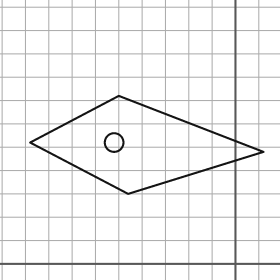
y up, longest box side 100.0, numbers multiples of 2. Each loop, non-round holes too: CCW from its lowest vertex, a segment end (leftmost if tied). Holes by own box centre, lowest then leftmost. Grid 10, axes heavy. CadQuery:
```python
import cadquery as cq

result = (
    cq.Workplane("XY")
    .moveTo(-46.0, 30.0)
    .lineTo(12.0, 48.0)
    .lineTo(-50.0, 72.0)
    .lineTo(-88.0, 52.0)
    .close()
    .moveTo(-52.0, 52.0)
    .circle(4.0)
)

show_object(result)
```